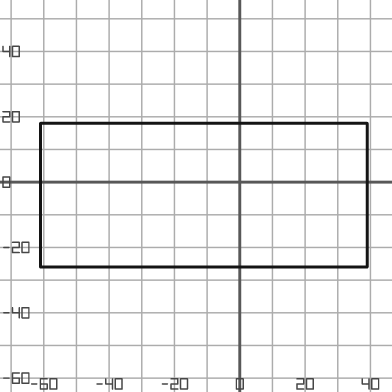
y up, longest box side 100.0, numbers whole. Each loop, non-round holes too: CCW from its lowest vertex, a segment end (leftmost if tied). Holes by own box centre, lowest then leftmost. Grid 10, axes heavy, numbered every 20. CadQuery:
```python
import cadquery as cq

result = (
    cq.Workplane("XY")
    .moveTo(-61.0, -26.0)
    .lineTo(39.0, -26.0)
    .lineTo(39.0, 18.0)
    .lineTo(-61.0, 18.0)
    .close()
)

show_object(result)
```